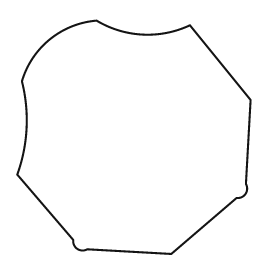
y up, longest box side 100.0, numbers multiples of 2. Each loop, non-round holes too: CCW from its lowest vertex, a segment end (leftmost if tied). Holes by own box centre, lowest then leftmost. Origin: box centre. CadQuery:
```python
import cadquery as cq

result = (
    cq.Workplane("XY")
    .moveTo(16.0, -50.0)
    .lineTo(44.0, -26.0)
    .threePointArc((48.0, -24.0), (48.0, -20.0))
    .lineTo(50.0, 16.0)
    .lineTo(24.0, 48.0)
    .threePointArc((4.0, 44.0), (-16.0, 50.0))
    .threePointArc((-36.0, 42.0), (-48.0, 24.0))
    .threePointArc((-46.0, 4.0), (-50.0, -16.0))
    .lineTo(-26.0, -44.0)
    .threePointArc((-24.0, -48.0), (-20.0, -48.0))
    .close()
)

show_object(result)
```